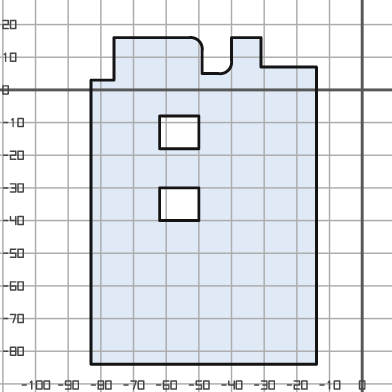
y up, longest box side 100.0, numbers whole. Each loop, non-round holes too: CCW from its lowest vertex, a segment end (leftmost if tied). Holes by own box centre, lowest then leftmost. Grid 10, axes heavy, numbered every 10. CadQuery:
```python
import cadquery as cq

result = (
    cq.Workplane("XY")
    .moveTo(-83.0, -84.0)
    .lineTo(-14.0, -84.0)
    .lineTo(-14.0, 7.0)
    .lineTo(-31.0, 7.0)
    .lineTo(-31.0, 16.0)
    .lineTo(-40.0, 16.0)
    .lineTo(-40.0, 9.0)
    .threePointArc((-41.0, 6.0), (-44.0, 5.0))
    .lineTo(-49.0, 5.0)
    .lineTo(-49.0, 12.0)
    .threePointArc((-50.0, 15.0), (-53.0, 16.0))
    .lineTo(-76.0, 16.0)
    .lineTo(-76.0, 3.0)
    .lineTo(-83.0, 3.0)
    .close()
    .moveTo(-62.0, -40.0)
    .lineTo(-50.0, -40.0)
    .lineTo(-50.0, -30.0)
    .lineTo(-62.0, -30.0)
    .close()
    .moveTo(-62.0, -18.0)
    .lineTo(-50.0, -18.0)
    .lineTo(-50.0, -8.0)
    .lineTo(-62.0, -8.0)
    .close()
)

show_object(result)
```